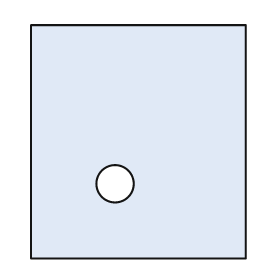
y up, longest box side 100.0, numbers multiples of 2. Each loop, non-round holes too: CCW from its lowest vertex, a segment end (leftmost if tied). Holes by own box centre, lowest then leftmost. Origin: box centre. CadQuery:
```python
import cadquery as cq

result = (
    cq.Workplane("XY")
    .moveTo(-46.0, -50.0)
    .lineTo(46.0, -50.0)
    .lineTo(46.0, 50.0)
    .lineTo(-46.0, 50.0)
    .close()
    .moveTo(-10.0, -18.0)
    .circle(8.0)
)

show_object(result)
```